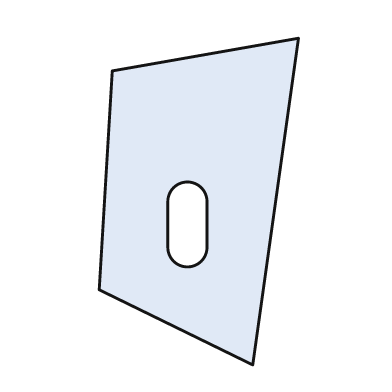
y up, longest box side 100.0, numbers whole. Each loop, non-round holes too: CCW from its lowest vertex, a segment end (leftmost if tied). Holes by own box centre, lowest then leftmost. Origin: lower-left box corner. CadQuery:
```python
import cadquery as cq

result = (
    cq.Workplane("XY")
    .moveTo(47.0, 0.0)
    .lineTo(61.0, 100.0)
    .lineTo(4.0, 90.0)
    .lineTo(0.0, 23.0)
    .close()
    .moveTo(21.0, 36.0)
    .threePointArc((27.0, 30.0), (33.0, 36.0))
    .lineTo(33.0, 50.0)
    .threePointArc((27.0, 56.0), (21.0, 50.0))
    .close()
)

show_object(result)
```